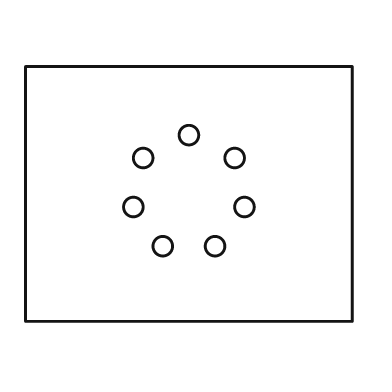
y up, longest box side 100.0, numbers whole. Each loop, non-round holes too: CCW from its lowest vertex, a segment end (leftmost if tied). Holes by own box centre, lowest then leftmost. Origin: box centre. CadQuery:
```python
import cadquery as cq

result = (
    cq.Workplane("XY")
    .moveTo(-50.0, -39.0)
    .lineTo(50.0, -39.0)
    .lineTo(50.0, 39.0)
    .lineTo(-50.0, 39.0)
    .close()
    .moveTo(-8.0, -16.0)
    .circle(3.0)
    .moveTo(8.0, -16.0)
    .circle(3.0)
    .moveTo(-17.0, -4.0)
    .circle(3.0)
    .moveTo(17.0, -4.0)
    .circle(3.0)
    .moveTo(-14.0, 11.0)
    .circle(3.0)
    .moveTo(14.0, 11.0)
    .circle(3.0)
    .moveTo(0.0, 18.0)
    .circle(3.0)
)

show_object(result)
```